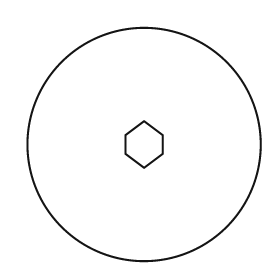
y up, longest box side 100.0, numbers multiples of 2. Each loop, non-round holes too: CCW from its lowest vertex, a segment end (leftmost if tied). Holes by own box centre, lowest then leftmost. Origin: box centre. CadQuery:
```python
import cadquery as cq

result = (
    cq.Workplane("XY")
    .moveTo(0.0, 0.0)
    .circle(50.0)
    .moveTo(0.0, -10.0)
    .lineTo(8.0, -4.0)
    .lineTo(8.0, 4.0)
    .lineTo(0.0, 10.0)
    .lineTo(-8.0, 4.0)
    .lineTo(-8.0, -4.0)
    .close()
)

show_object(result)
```